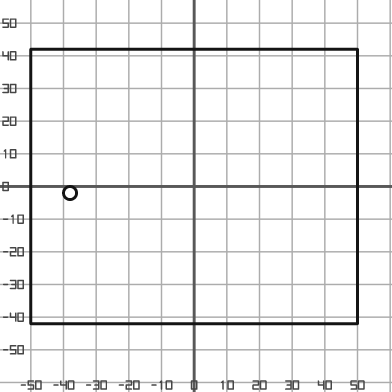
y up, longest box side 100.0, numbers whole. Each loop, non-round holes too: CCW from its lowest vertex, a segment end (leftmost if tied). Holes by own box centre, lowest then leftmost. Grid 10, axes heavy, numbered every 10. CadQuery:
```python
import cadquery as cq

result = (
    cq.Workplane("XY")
    .moveTo(-50.0, -42.0)
    .lineTo(50.0, -42.0)
    .lineTo(50.0, 42.0)
    .lineTo(-50.0, 42.0)
    .close()
    .moveTo(-38.0, -2.0)
    .circle(2.0)
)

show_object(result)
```